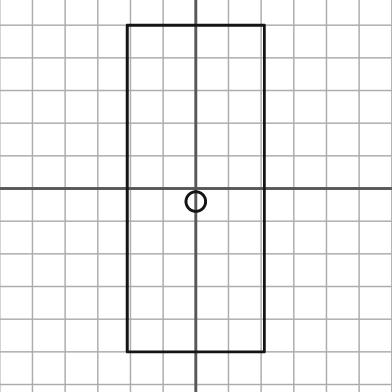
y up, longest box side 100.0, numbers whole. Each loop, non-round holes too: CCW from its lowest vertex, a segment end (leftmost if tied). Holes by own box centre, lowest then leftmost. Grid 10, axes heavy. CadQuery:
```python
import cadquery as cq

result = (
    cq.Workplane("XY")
    .moveTo(-21.0, -50.0)
    .lineTo(21.0, -50.0)
    .lineTo(21.0, 50.0)
    .lineTo(-21.0, 50.0)
    .close()
    .moveTo(0.0, -4.0)
    .circle(3.0)
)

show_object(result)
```